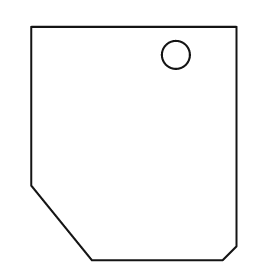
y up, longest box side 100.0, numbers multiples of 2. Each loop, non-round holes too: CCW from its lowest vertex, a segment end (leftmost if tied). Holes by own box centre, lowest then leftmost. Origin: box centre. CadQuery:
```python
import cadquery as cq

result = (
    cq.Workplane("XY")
    .moveTo(-18.0, -50.0)
    .lineTo(38.0, -50.0)
    .lineTo(44.0, -44.0)
    .lineTo(44.0, 50.0)
    .lineTo(-44.0, 50.0)
    .lineTo(-44.0, -18.0)
    .close()
    .moveTo(18.0, 38.0)
    .circle(6.0)
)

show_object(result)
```